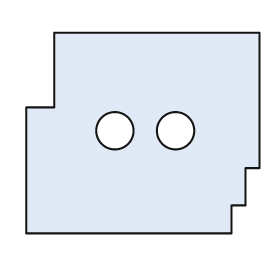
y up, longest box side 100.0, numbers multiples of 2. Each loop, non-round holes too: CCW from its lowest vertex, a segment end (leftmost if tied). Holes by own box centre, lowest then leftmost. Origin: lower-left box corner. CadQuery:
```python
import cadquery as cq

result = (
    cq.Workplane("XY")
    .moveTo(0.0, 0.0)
    .lineTo(88.0, 0.0)
    .lineTo(88.0, 12.0)
    .lineTo(94.0, 12.0)
    .lineTo(94.0, 28.0)
    .lineTo(100.0, 28.0)
    .lineTo(100.0, 86.0)
    .lineTo(12.0, 86.0)
    .lineTo(12.0, 54.0)
    .lineTo(0.0, 54.0)
    .close()
    .moveTo(38.0, 44.0)
    .circle(8.0)
    .moveTo(64.0, 44.0)
    .circle(8.0)
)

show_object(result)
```